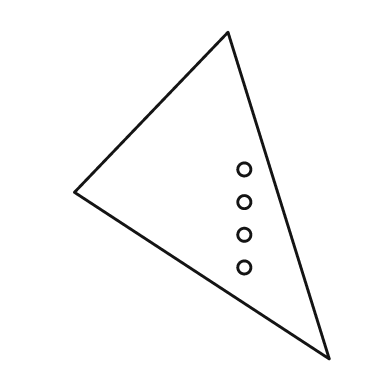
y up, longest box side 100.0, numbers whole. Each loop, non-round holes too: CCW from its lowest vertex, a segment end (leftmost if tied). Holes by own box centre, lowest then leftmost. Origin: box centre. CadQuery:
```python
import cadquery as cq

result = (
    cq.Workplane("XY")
    .moveTo(39.0, -50.0)
    .lineTo(8.0, 50.0)
    .lineTo(-39.0, 1.0)
    .close()
    .moveTo(13.0, -22.0)
    .circle(2.0)
    .moveTo(13.0, -12.0)
    .circle(2.0)
    .moveTo(13.0, -2.0)
    .circle(2.0)
    .moveTo(13.0, 8.0)
    .circle(2.0)
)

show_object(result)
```